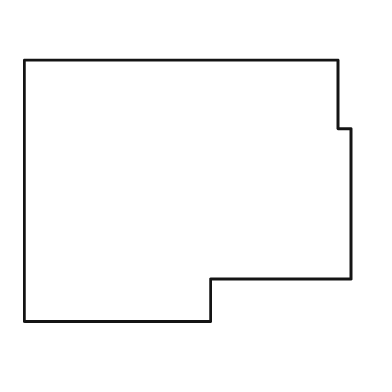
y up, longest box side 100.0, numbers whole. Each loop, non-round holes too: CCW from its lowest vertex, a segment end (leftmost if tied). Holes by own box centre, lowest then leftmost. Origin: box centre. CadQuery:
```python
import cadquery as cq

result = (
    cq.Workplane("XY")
    .moveTo(-50.0, -40.0)
    .lineTo(7.0, -40.0)
    .lineTo(7.0, -27.0)
    .lineTo(50.0, -27.0)
    .lineTo(50.0, 19.0)
    .lineTo(46.0, 19.0)
    .lineTo(46.0, 40.0)
    .lineTo(-50.0, 40.0)
    .close()
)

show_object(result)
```